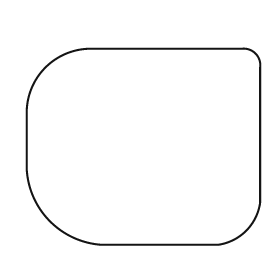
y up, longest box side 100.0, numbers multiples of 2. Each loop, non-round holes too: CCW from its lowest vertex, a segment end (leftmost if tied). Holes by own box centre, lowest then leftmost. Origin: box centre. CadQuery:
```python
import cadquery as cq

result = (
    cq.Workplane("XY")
    .moveTo(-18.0, -42.0)
    .lineTo(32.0, -42.0)
    .threePointArc((44.0, -36.0), (50.0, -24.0))
    .lineTo(50.0, 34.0)
    .threePointArc((48.0, 40.0), (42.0, 42.0))
    .lineTo(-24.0, 42.0)
    .threePointArc((-42.0, 34.0), (-50.0, 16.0))
    .lineTo(-50.0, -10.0)
    .threePointArc((-40.0, -32.0), (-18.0, -42.0))
    .close()
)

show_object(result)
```